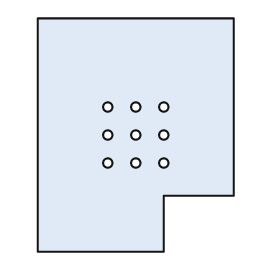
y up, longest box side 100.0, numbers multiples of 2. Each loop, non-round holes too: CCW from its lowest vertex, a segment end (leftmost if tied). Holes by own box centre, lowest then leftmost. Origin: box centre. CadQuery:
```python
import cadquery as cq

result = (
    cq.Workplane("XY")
    .moveTo(-42.0, -50.0)
    .lineTo(12.0, -50.0)
    .lineTo(12.0, -26.0)
    .lineTo(42.0, -26.0)
    .lineTo(42.0, 50.0)
    .lineTo(-42.0, 50.0)
    .close()
    .moveTo(-12.0, -12.0)
    .circle(2.0)
    .moveTo(0.0, -12.0)
    .circle(2.0)
    .moveTo(12.0, -12.0)
    .circle(2.0)
    .moveTo(-12.0, 0.0)
    .circle(2.0)
    .moveTo(0.0, 0.0)
    .circle(2.0)
    .moveTo(12.0, 0.0)
    .circle(2.0)
    .moveTo(-12.0, 12.0)
    .circle(2.0)
    .moveTo(0.0, 12.0)
    .circle(2.0)
    .moveTo(12.0, 12.0)
    .circle(2.0)
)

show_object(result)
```